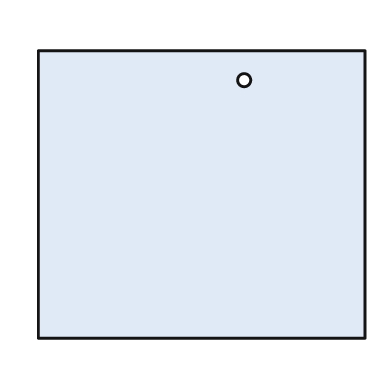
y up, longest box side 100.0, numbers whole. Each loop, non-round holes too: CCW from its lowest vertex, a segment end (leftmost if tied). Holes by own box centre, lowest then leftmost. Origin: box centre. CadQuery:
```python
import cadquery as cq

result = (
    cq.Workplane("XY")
    .moveTo(-50.0, -44.0)
    .lineTo(50.0, -44.0)
    .lineTo(50.0, 44.0)
    .lineTo(-50.0, 44.0)
    .close()
    .moveTo(13.0, 35.0)
    .circle(2.0)
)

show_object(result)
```